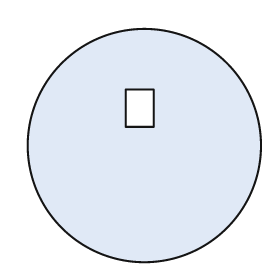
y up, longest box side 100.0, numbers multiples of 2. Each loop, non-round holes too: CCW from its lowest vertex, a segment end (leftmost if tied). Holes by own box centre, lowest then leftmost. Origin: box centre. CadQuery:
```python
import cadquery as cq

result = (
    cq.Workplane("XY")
    .moveTo(0.0, 0.0)
    .circle(50.0)
    .moveTo(-8.0, 8.0)
    .lineTo(4.0, 8.0)
    .lineTo(4.0, 24.0)
    .lineTo(-8.0, 24.0)
    .close()
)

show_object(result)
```